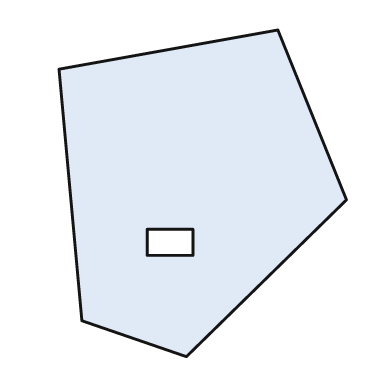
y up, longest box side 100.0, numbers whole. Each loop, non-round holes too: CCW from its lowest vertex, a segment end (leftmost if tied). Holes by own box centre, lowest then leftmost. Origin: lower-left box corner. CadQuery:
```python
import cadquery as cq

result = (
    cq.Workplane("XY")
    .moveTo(39.0, 0.0)
    .lineTo(88.0, 48.0)
    .lineTo(67.0, 100.0)
    .lineTo(0.0, 88.0)
    .lineTo(7.0, 11.0)
    .close()
    .moveTo(27.0, 31.0)
    .lineTo(41.0, 31.0)
    .lineTo(41.0, 39.0)
    .lineTo(27.0, 39.0)
    .close()
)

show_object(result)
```